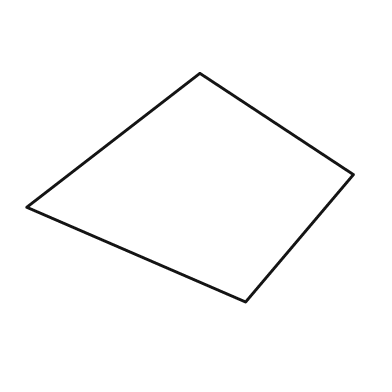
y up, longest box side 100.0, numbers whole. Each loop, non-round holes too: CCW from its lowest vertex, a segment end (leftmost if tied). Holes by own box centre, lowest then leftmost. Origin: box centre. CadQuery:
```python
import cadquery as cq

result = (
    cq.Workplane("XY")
    .moveTo(17.0, -35.0)
    .lineTo(50.0, 4.0)
    .lineTo(3.0, 35.0)
    .lineTo(-50.0, -6.0)
    .close()
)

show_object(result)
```